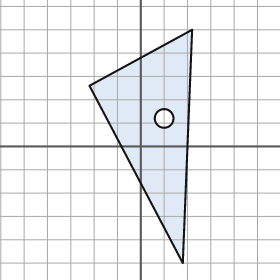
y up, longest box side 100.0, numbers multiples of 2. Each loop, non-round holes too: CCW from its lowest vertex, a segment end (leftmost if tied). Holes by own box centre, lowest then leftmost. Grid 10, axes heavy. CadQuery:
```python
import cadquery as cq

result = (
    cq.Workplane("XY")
    .moveTo(18.0, -50.0)
    .lineTo(22.0, 50.0)
    .lineTo(-22.0, 26.0)
    .close()
    .moveTo(10.0, 12.0)
    .circle(4.0)
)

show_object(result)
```